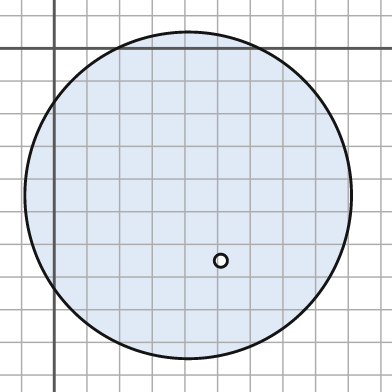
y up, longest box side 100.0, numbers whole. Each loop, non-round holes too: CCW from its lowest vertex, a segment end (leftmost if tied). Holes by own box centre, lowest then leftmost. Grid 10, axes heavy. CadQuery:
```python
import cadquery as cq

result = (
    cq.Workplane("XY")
    .moveTo(41.0, -45.0)
    .circle(50.0)
    .moveTo(51.0, -65.0)
    .circle(2.0)
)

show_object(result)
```